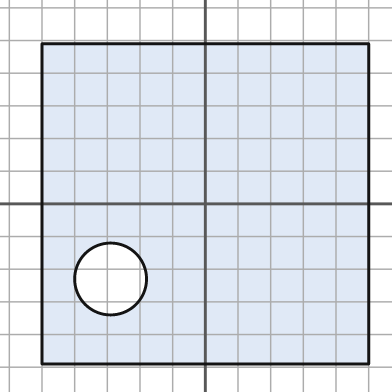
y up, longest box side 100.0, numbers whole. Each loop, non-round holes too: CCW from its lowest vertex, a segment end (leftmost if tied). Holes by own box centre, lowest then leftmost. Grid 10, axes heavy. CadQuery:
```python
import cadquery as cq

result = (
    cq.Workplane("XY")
    .moveTo(-50.0, -49.0)
    .lineTo(50.0, -49.0)
    .lineTo(50.0, 49.0)
    .lineTo(-50.0, 49.0)
    .close()
    .moveTo(-29.0, -23.0)
    .circle(11.0)
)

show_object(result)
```